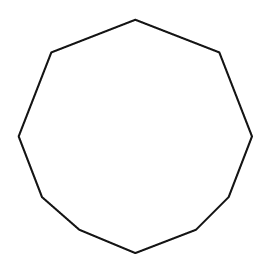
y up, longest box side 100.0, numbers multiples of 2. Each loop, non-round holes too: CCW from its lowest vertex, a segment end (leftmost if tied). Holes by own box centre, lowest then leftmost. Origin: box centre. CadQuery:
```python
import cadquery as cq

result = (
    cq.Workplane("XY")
    .moveTo(0.0, -50.0)
    .lineTo(26.0, -40.0)
    .lineTo(40.0, -26.0)
    .lineTo(50.0, 0.0)
    .lineTo(36.0, 36.0)
    .lineTo(0.0, 50.0)
    .lineTo(-36.0, 36.0)
    .lineTo(-50.0, 0.0)
    .lineTo(-40.0, -26.0)
    .lineTo(-24.0, -40.0)
    .close()
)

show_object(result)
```